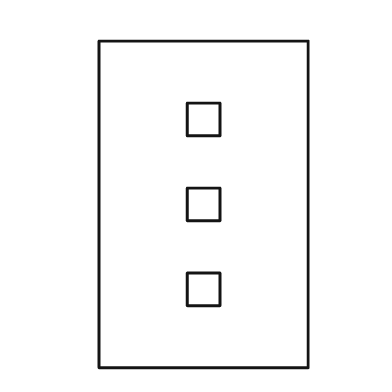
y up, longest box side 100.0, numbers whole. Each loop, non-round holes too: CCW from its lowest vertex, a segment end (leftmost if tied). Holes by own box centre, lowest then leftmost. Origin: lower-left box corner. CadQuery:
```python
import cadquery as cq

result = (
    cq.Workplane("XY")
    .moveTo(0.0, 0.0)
    .lineTo(64.0, 0.0)
    .lineTo(64.0, 100.0)
    .lineTo(0.0, 100.0)
    .close()
    .moveTo(27.0, 19.0)
    .lineTo(37.0, 19.0)
    .lineTo(37.0, 29.0)
    .lineTo(27.0, 29.0)
    .close()
    .moveTo(27.0, 45.0)
    .lineTo(37.0, 45.0)
    .lineTo(37.0, 55.0)
    .lineTo(27.0, 55.0)
    .close()
    .moveTo(27.0, 71.0)
    .lineTo(37.0, 71.0)
    .lineTo(37.0, 81.0)
    .lineTo(27.0, 81.0)
    .close()
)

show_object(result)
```